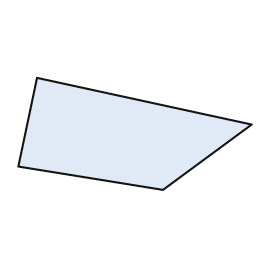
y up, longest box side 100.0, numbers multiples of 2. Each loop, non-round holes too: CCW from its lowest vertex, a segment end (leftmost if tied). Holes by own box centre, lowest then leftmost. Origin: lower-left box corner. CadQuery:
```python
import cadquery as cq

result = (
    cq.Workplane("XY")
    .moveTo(62.0, 0.0)
    .lineTo(100.0, 28.0)
    .lineTo(8.0, 48.0)
    .lineTo(0.0, 10.0)
    .close()
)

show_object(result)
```